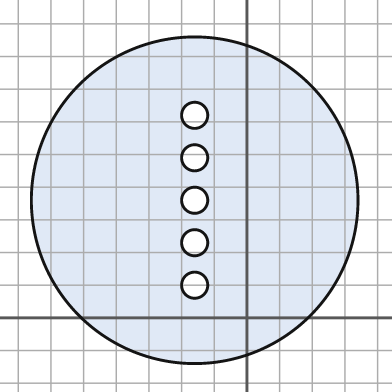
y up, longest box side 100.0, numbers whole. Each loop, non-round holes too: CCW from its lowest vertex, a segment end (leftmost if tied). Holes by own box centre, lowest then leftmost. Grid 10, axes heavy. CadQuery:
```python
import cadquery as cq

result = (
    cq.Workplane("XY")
    .moveTo(-16.0, 36.0)
    .circle(50.0)
    .moveTo(-16.0, 10.0)
    .circle(4.0)
    .moveTo(-16.0, 23.0)
    .circle(4.0)
    .moveTo(-16.0, 36.0)
    .circle(4.0)
    .moveTo(-16.0, 49.0)
    .circle(4.0)
    .moveTo(-16.0, 62.0)
    .circle(4.0)
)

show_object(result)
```